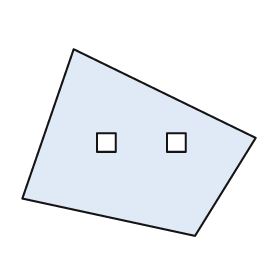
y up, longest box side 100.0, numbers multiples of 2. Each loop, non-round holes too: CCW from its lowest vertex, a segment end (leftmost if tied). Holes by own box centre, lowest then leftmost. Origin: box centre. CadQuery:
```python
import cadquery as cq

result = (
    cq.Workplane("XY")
    .moveTo(24.0, -40.0)
    .lineTo(50.0, 2.0)
    .lineTo(-28.0, 40.0)
    .lineTo(-50.0, -24.0)
    .close()
    .moveTo(-18.0, -4.0)
    .lineTo(-10.0, -4.0)
    .lineTo(-10.0, 4.0)
    .lineTo(-18.0, 4.0)
    .close()
    .moveTo(12.0, -4.0)
    .lineTo(20.0, -4.0)
    .lineTo(20.0, 4.0)
    .lineTo(12.0, 4.0)
    .close()
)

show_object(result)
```